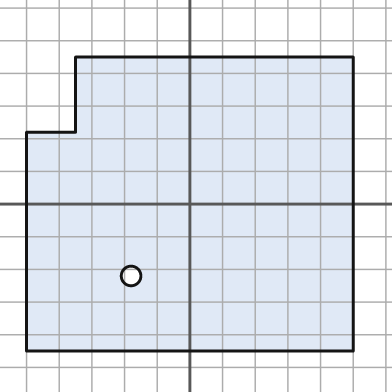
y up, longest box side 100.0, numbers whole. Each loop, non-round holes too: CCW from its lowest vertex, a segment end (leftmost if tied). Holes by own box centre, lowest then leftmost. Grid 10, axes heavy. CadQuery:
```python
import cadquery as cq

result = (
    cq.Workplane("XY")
    .moveTo(-50.0, -45.0)
    .lineTo(50.0, -45.0)
    .lineTo(50.0, 45.0)
    .lineTo(-35.0, 45.0)
    .lineTo(-35.0, 22.0)
    .lineTo(-50.0, 22.0)
    .close()
    .moveTo(-18.0, -22.0)
    .circle(3.0)
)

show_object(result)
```